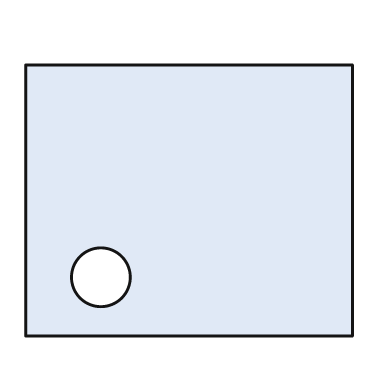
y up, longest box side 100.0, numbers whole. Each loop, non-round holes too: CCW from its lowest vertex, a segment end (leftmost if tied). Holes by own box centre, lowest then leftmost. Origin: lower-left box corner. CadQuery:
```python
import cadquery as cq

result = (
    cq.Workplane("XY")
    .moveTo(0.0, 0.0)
    .lineTo(100.0, 0.0)
    .lineTo(100.0, 83.0)
    .lineTo(0.0, 83.0)
    .close()
    .moveTo(23.0, 18.0)
    .circle(9.0)
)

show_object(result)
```